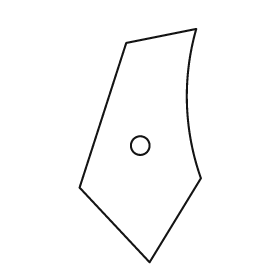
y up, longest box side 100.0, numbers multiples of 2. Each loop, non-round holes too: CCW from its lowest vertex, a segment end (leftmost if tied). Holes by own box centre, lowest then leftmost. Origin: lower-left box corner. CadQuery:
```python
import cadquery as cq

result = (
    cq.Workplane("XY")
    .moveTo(30.0, 0.0)
    .lineTo(52.0, 36.0)
    .threePointArc((46.0, 68.0), (50.0, 100.0))
    .lineTo(20.0, 94.0)
    .lineTo(0.0, 32.0)
    .close()
    .moveTo(26.0, 50.0)
    .circle(4.0)
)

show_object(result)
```